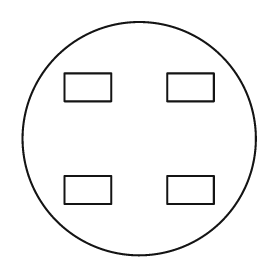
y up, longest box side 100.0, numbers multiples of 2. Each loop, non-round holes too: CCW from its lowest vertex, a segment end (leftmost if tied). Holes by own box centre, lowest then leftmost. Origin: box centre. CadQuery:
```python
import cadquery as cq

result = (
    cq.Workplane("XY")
    .moveTo(0.0, 0.0)
    .circle(50.0)
    .moveTo(-32.0, -28.0)
    .lineTo(-12.0, -28.0)
    .lineTo(-12.0, -16.0)
    .lineTo(-32.0, -16.0)
    .close()
    .moveTo(12.0, -28.0)
    .lineTo(32.0, -28.0)
    .lineTo(32.0, -16.0)
    .lineTo(12.0, -16.0)
    .close()
    .moveTo(-32.0, 16.0)
    .lineTo(-12.0, 16.0)
    .lineTo(-12.0, 28.0)
    .lineTo(-32.0, 28.0)
    .close()
    .moveTo(12.0, 16.0)
    .lineTo(32.0, 16.0)
    .lineTo(32.0, 28.0)
    .lineTo(12.0, 28.0)
    .close()
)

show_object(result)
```